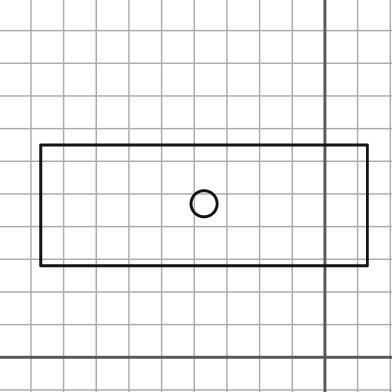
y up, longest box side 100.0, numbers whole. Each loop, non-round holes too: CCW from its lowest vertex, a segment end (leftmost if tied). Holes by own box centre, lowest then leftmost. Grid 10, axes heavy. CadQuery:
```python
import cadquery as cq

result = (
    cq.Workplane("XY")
    .moveTo(-87.0, 28.0)
    .lineTo(13.0, 28.0)
    .lineTo(13.0, 65.0)
    .lineTo(-87.0, 65.0)
    .close()
    .moveTo(-37.0, 47.0)
    .circle(4.0)
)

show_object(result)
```